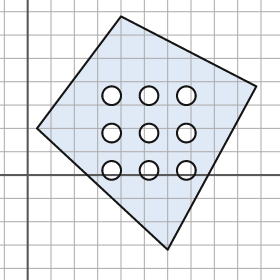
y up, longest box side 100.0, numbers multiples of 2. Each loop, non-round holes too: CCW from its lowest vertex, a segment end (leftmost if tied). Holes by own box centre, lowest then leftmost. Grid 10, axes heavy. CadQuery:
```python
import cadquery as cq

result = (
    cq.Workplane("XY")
    .moveTo(60.0, -32.0)
    .lineTo(98.0, 38.0)
    .lineTo(40.0, 68.0)
    .lineTo(4.0, 20.0)
    .close()
    .moveTo(36.0, 2.0)
    .circle(4.0)
    .moveTo(52.0, 2.0)
    .circle(4.0)
    .moveTo(68.0, 2.0)
    .circle(4.0)
    .moveTo(36.0, 18.0)
    .circle(4.0)
    .moveTo(52.0, 18.0)
    .circle(4.0)
    .moveTo(68.0, 18.0)
    .circle(4.0)
    .moveTo(36.0, 34.0)
    .circle(4.0)
    .moveTo(52.0, 34.0)
    .circle(4.0)
    .moveTo(68.0, 34.0)
    .circle(4.0)
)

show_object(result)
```